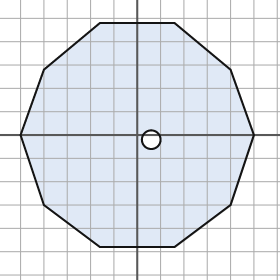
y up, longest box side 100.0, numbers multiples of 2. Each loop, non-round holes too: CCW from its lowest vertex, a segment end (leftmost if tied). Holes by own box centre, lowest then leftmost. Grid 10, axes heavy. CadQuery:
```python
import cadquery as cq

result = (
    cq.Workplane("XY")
    .moveTo(-16.0, -48.0)
    .lineTo(16.0, -48.0)
    .lineTo(40.0, -30.0)
    .lineTo(50.0, 0.0)
    .lineTo(40.0, 28.0)
    .lineTo(16.0, 48.0)
    .lineTo(-16.0, 48.0)
    .lineTo(-40.0, 28.0)
    .lineTo(-50.0, 0.0)
    .lineTo(-40.0, -30.0)
    .close()
    .moveTo(6.0, -2.0)
    .circle(4.0)
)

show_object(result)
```